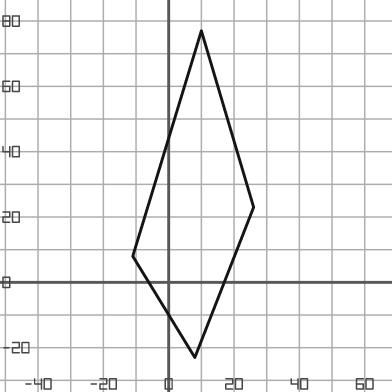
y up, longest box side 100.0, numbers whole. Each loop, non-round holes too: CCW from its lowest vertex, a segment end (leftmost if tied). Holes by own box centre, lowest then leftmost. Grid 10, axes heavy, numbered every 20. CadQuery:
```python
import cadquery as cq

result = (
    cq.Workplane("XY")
    .moveTo(8.0, -23.0)
    .lineTo(26.0, 23.0)
    .lineTo(10.0, 77.0)
    .lineTo(-11.0, 8.0)
    .close()
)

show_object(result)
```